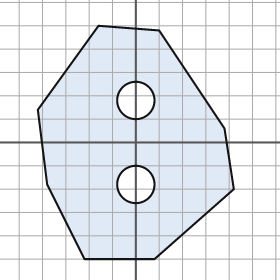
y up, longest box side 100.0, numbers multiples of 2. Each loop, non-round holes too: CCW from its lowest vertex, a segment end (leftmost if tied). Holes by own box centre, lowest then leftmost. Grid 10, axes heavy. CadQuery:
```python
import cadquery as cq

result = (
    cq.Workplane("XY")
    .moveTo(-22.0, -50.0)
    .lineTo(8.0, -50.0)
    .lineTo(42.0, -20.0)
    .lineTo(38.0, 6.0)
    .lineTo(10.0, 48.0)
    .lineTo(-16.0, 50.0)
    .lineTo(-42.0, 14.0)
    .lineTo(-38.0, -18.0)
    .close()
    .moveTo(0.0, -18.0)
    .circle(8.0)
    .moveTo(0.0, 18.0)
    .circle(8.0)
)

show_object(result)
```